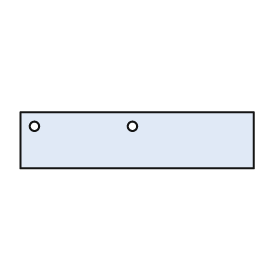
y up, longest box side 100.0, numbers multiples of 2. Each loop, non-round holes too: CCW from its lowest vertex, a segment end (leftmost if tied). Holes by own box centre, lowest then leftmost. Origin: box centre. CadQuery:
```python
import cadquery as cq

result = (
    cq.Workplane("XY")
    .moveTo(-50.0, -12.0)
    .lineTo(50.0, -12.0)
    .lineTo(50.0, 12.0)
    .lineTo(-50.0, 12.0)
    .close()
    .moveTo(-44.0, 6.0)
    .circle(2.0)
    .moveTo(-2.0, 6.0)
    .circle(2.0)
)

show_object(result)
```